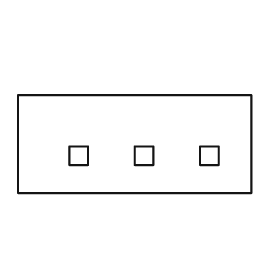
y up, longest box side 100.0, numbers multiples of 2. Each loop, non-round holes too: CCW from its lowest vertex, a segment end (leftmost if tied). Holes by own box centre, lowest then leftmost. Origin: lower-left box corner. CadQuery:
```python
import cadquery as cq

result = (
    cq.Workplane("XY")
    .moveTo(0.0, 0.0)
    .lineTo(100.0, 0.0)
    .lineTo(100.0, 42.0)
    .lineTo(0.0, 42.0)
    .close()
    .moveTo(22.0, 12.0)
    .lineTo(30.0, 12.0)
    .lineTo(30.0, 20.0)
    .lineTo(22.0, 20.0)
    .close()
    .moveTo(50.0, 12.0)
    .lineTo(58.0, 12.0)
    .lineTo(58.0, 20.0)
    .lineTo(50.0, 20.0)
    .close()
    .moveTo(78.0, 12.0)
    .lineTo(86.0, 12.0)
    .lineTo(86.0, 20.0)
    .lineTo(78.0, 20.0)
    .close()
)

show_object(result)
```